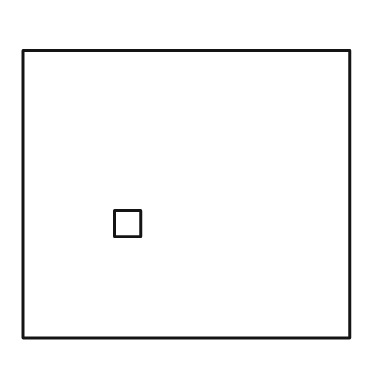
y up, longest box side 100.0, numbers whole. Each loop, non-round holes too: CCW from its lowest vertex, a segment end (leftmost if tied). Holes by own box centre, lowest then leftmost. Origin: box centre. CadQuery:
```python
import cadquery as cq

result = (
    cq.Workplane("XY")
    .moveTo(-50.0, -44.0)
    .lineTo(50.0, -44.0)
    .lineTo(50.0, 44.0)
    .lineTo(-50.0, 44.0)
    .close()
    .moveTo(-22.0, -13.0)
    .lineTo(-14.0, -13.0)
    .lineTo(-14.0, -5.0)
    .lineTo(-22.0, -5.0)
    .close()
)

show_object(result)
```